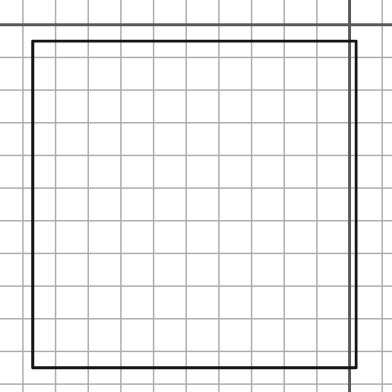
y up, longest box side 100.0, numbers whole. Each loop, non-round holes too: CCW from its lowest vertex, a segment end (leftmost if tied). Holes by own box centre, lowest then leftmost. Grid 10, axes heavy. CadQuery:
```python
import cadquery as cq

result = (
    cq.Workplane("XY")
    .moveTo(-97.0, -105.0)
    .lineTo(2.0, -105.0)
    .lineTo(2.0, -5.0)
    .lineTo(-97.0, -5.0)
    .close()
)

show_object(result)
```